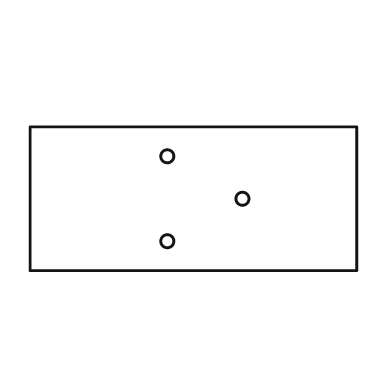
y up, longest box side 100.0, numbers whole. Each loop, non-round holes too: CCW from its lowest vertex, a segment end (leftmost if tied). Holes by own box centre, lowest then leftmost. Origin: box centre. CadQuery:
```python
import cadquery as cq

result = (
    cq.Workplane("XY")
    .moveTo(-50.0, -22.0)
    .lineTo(50.0, -22.0)
    .lineTo(50.0, 22.0)
    .lineTo(-50.0, 22.0)
    .close()
    .moveTo(-8.0, -13.0)
    .circle(2.0)
    .moveTo(15.0, 0.0)
    .circle(2.0)
    .moveTo(-8.0, 13.0)
    .circle(2.0)
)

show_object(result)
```